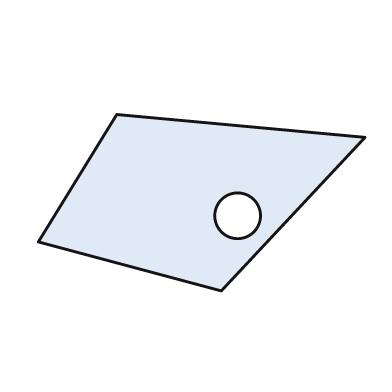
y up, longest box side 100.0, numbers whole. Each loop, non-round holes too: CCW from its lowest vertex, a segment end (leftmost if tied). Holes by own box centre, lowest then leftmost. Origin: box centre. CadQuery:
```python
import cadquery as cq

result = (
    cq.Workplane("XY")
    .moveTo(6.0, -27.0)
    .lineTo(50.0, 20.0)
    .lineTo(-26.0, 27.0)
    .lineTo(-50.0, -12.0)
    .close()
    .moveTo(11.0, -4.0)
    .circle(7.0)
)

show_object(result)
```